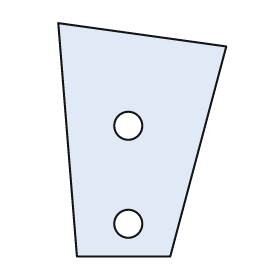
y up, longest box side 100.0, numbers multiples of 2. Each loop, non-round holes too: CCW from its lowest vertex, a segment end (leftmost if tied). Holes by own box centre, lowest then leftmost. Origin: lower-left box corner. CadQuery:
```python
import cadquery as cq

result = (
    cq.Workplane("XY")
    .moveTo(8.0, 0.0)
    .lineTo(48.0, 0.0)
    .lineTo(72.0, 90.0)
    .lineTo(0.0, 100.0)
    .close()
    .moveTo(30.0, 14.0)
    .circle(6.0)
    .moveTo(30.0, 56.0)
    .circle(6.0)
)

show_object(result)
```